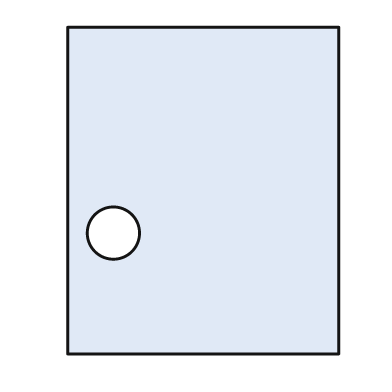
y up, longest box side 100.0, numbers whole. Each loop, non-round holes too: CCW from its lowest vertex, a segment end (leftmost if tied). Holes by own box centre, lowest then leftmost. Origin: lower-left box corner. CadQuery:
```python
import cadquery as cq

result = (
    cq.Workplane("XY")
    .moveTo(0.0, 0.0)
    .lineTo(83.0, 0.0)
    .lineTo(83.0, 100.0)
    .lineTo(0.0, 100.0)
    .close()
    .moveTo(14.0, 37.0)
    .circle(8.0)
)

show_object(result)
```